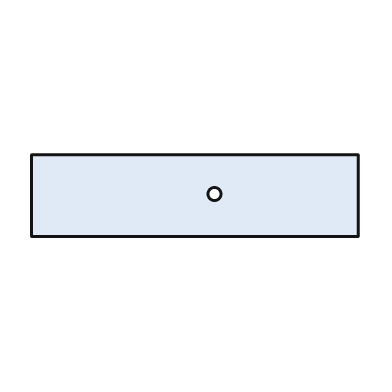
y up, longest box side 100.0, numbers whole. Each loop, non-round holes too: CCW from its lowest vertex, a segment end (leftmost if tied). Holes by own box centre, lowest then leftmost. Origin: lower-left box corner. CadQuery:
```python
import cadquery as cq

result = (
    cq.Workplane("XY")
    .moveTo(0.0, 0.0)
    .lineTo(100.0, 0.0)
    .lineTo(100.0, 25.0)
    .lineTo(0.0, 25.0)
    .close()
    .moveTo(56.0, 13.0)
    .circle(2.0)
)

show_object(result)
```